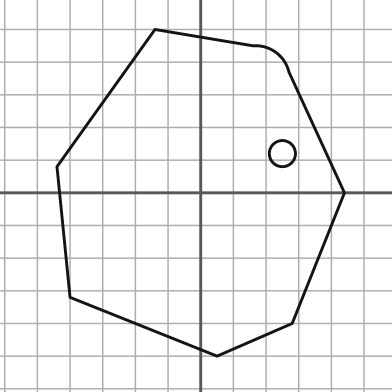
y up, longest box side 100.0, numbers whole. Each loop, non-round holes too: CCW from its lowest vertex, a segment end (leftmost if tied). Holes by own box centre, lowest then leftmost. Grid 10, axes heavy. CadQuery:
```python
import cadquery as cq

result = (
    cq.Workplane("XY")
    .moveTo(5.0, -50.0)
    .lineTo(28.0, -40.0)
    .lineTo(44.0, 0.0)
    .lineTo(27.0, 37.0)
    .threePointArc((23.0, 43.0), (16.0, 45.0))
    .lineTo(-14.0, 50.0)
    .lineTo(-44.0, 8.0)
    .lineTo(-40.0, -32.0)
    .close()
    .moveTo(25.0, 12.0)
    .circle(4.0)
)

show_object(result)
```